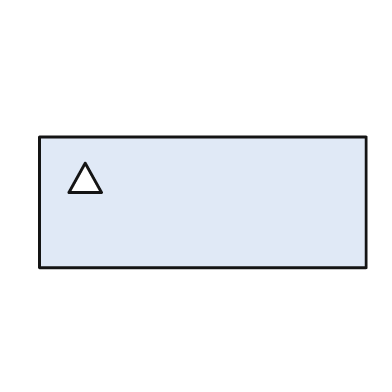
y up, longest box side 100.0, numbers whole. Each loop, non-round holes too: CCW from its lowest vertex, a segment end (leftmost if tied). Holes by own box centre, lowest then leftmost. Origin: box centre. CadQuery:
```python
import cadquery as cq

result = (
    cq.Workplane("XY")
    .moveTo(-50.0, -20.0)
    .lineTo(50.0, -20.0)
    .lineTo(50.0, 20.0)
    .lineTo(-50.0, 20.0)
    .close()
    .moveTo(-41.0, 3.0)
    .lineTo(-31.0, 3.0)
    .lineTo(-36.0, 12.0)
    .close()
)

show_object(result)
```